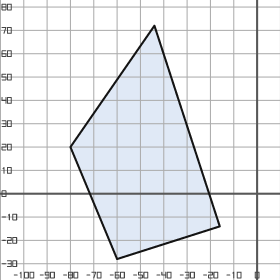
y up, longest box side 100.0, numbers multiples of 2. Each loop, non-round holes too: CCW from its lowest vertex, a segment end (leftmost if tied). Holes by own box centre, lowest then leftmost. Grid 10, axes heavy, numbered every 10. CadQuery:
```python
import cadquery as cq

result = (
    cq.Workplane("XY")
    .moveTo(-60.0, -28.0)
    .lineTo(-16.0, -14.0)
    .lineTo(-44.0, 72.0)
    .lineTo(-80.0, 20.0)
    .close()
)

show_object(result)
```